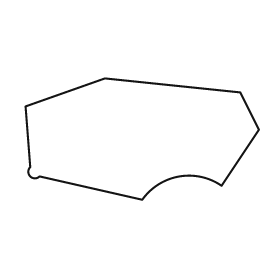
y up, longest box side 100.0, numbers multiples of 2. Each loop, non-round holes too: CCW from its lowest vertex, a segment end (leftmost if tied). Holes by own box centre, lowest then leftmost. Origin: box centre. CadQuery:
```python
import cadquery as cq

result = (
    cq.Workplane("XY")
    .moveTo(0.0, -26.0)
    .threePointArc((16.0, -16.0), (34.0, -20.0))
    .lineTo(50.0, 4.0)
    .lineTo(42.0, 20.0)
    .lineTo(-16.0, 26.0)
    .lineTo(-50.0, 14.0)
    .lineTo(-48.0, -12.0)
    .threePointArc((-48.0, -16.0), (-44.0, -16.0))
    .close()
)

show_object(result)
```